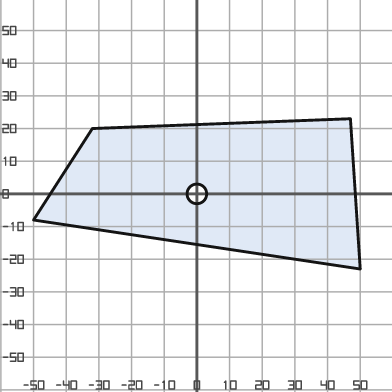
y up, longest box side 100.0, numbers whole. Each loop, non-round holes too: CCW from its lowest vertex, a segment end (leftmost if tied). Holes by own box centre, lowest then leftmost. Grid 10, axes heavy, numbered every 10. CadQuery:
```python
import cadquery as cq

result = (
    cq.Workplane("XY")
    .moveTo(50.0, -23.0)
    .lineTo(47.0, 23.0)
    .lineTo(-32.0, 20.0)
    .lineTo(-50.0, -8.0)
    .close()
    .moveTo(0.0, 0.0)
    .circle(3.0)
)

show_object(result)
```